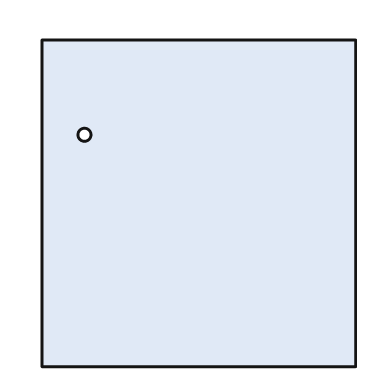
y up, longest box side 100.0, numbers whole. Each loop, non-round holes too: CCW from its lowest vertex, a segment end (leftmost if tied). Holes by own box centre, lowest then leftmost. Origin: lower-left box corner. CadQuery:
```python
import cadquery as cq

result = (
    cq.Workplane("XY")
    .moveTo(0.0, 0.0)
    .lineTo(96.0, 0.0)
    .lineTo(96.0, 100.0)
    .lineTo(0.0, 100.0)
    .close()
    .moveTo(13.0, 71.0)
    .circle(2.0)
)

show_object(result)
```